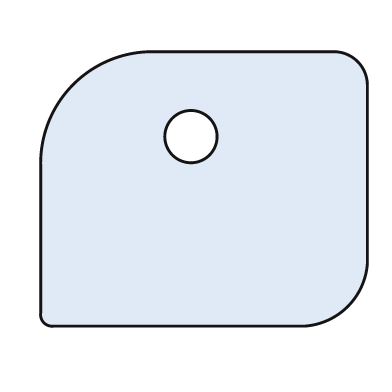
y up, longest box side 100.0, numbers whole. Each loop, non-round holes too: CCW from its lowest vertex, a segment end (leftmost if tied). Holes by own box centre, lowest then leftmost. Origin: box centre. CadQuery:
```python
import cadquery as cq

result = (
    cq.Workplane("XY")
    .moveTo(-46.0, -42.0)
    .lineTo(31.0, -42.0)
    .threePointArc((44.0, -36.0), (50.0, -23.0))
    .lineTo(50.0, 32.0)
    .threePointArc((47.0, 39.0), (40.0, 42.0))
    .lineTo(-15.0, 42.0)
    .threePointArc((-40.0, 32.0), (-50.0, 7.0))
    .lineTo(-50.0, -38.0)
    .threePointArc((-49.0, -41.0), (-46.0, -42.0))
    .close()
    .moveTo(-4.0, 16.0)
    .circle(8.0)
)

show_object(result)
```